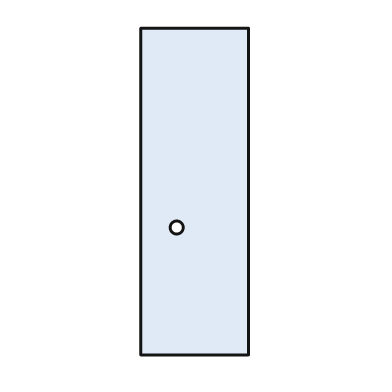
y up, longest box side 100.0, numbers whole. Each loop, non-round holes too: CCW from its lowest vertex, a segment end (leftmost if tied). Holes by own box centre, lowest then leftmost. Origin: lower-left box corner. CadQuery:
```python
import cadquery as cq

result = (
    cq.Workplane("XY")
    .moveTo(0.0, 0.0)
    .lineTo(33.0, 0.0)
    .lineTo(33.0, 100.0)
    .lineTo(0.0, 100.0)
    .close()
    .moveTo(11.0, 39.0)
    .circle(2.0)
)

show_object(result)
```